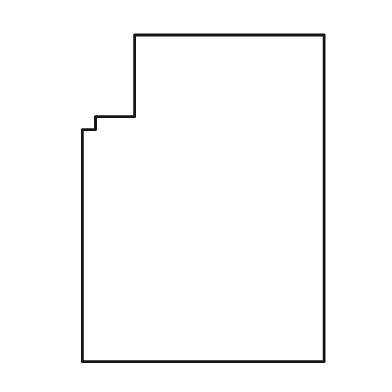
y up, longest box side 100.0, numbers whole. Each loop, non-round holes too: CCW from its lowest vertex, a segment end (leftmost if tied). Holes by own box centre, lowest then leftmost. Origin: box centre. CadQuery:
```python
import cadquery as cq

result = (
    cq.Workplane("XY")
    .moveTo(-37.0, -50.0)
    .lineTo(37.0, -50.0)
    .lineTo(37.0, 50.0)
    .lineTo(-21.0, 50.0)
    .lineTo(-21.0, 25.0)
    .lineTo(-33.0, 25.0)
    .lineTo(-33.0, 21.0)
    .lineTo(-37.0, 21.0)
    .close()
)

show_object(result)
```